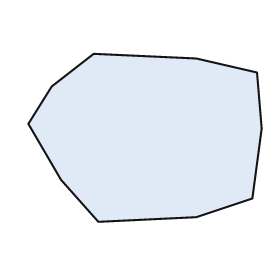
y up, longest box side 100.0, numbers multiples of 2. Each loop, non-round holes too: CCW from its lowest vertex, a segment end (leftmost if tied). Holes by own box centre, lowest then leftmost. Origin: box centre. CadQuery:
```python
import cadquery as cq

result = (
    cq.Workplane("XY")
    .moveTo(-20.0, -36.0)
    .lineTo(22.0, -34.0)
    .lineTo(46.0, -26.0)
    .lineTo(50.0, 4.0)
    .lineTo(48.0, 28.0)
    .lineTo(22.0, 34.0)
    .lineTo(-22.0, 36.0)
    .lineTo(-40.0, 22.0)
    .lineTo(-50.0, 6.0)
    .lineTo(-36.0, -18.0)
    .close()
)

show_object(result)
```